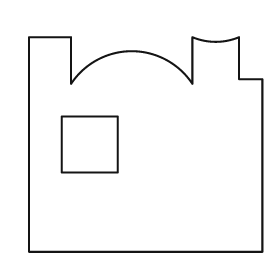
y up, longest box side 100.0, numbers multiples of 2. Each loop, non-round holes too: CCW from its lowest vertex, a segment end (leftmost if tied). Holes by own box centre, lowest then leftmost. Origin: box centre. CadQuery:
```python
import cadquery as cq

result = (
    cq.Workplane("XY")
    .moveTo(-50.0, -46.0)
    .lineTo(50.0, -46.0)
    .lineTo(50.0, 28.0)
    .lineTo(40.0, 28.0)
    .lineTo(40.0, 46.0)
    .threePointArc((30.0, 44.0), (20.0, 46.0))
    .lineTo(20.0, 26.0)
    .threePointArc((-6.0, 40.0), (-32.0, 26.0))
    .lineTo(-32.0, 46.0)
    .lineTo(-50.0, 46.0)
    .close()
    .moveTo(-36.0, -12.0)
    .lineTo(-12.0, -12.0)
    .lineTo(-12.0, 12.0)
    .lineTo(-36.0, 12.0)
    .close()
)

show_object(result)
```